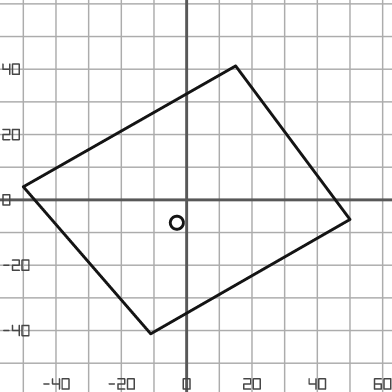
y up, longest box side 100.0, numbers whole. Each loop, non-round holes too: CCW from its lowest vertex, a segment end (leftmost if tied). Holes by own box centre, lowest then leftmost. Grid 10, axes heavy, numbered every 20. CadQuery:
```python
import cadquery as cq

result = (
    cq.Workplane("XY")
    .moveTo(-11.0, -41.0)
    .lineTo(50.0, -6.0)
    .lineTo(15.0, 41.0)
    .lineTo(-50.0, 4.0)
    .close()
    .moveTo(-3.0, -7.0)
    .circle(2.0)
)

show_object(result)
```